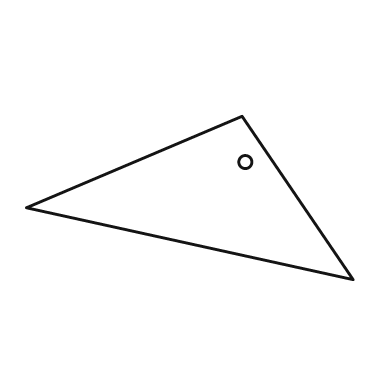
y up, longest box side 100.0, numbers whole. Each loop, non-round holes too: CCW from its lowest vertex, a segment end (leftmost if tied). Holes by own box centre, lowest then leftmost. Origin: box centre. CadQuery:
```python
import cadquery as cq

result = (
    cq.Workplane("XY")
    .moveTo(50.0, -25.0)
    .lineTo(16.0, 25.0)
    .lineTo(-50.0, -3.0)
    .close()
    .moveTo(17.0, 11.0)
    .circle(2.0)
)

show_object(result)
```